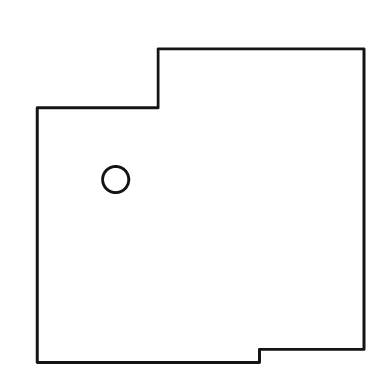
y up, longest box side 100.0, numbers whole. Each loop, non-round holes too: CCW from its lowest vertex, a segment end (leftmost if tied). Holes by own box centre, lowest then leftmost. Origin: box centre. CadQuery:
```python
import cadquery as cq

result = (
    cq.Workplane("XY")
    .moveTo(-50.0, -48.0)
    .lineTo(18.0, -48.0)
    .lineTo(18.0, -44.0)
    .lineTo(50.0, -44.0)
    .lineTo(50.0, 48.0)
    .lineTo(-13.0, 48.0)
    .lineTo(-13.0, 30.0)
    .lineTo(-50.0, 30.0)
    .close()
    .moveTo(-26.0, 8.0)
    .circle(4.0)
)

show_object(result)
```